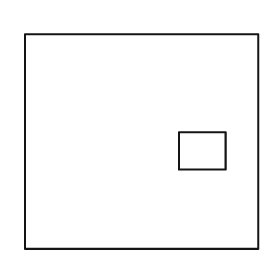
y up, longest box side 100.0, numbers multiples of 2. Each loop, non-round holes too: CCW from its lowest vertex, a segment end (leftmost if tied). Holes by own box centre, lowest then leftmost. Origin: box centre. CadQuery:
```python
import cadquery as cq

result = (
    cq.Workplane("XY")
    .moveTo(-50.0, -46.0)
    .lineTo(50.0, -46.0)
    .lineTo(50.0, 46.0)
    .lineTo(-50.0, 46.0)
    .close()
    .moveTo(16.0, -12.0)
    .lineTo(36.0, -12.0)
    .lineTo(36.0, 4.0)
    .lineTo(16.0, 4.0)
    .close()
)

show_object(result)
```